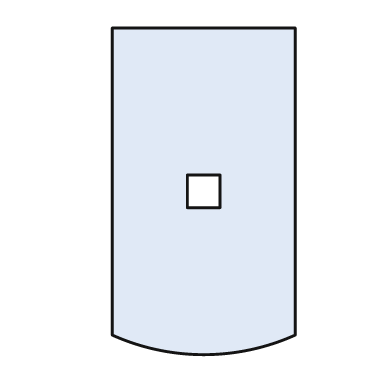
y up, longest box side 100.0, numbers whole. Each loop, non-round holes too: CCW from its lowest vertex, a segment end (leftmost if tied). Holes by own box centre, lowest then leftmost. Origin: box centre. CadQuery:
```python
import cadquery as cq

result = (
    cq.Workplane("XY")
    .moveTo(-28.0, -44.0)
    .threePointArc((0.0, -50.0), (28.0, -44.0))
    .lineTo(28.0, 50.0)
    .lineTo(-28.0, 50.0)
    .close()
    .moveTo(-5.0, -5.0)
    .lineTo(5.0, -5.0)
    .lineTo(5.0, 5.0)
    .lineTo(-5.0, 5.0)
    .close()
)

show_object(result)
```